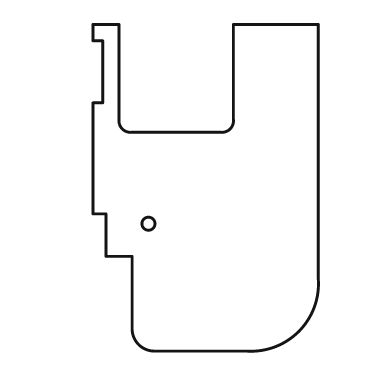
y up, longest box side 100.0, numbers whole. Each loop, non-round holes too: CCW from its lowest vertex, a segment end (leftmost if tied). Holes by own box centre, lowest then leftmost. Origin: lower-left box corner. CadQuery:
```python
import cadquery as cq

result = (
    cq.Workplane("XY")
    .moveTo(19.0, 0.0)
    .lineTo(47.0, 0.0)
    .threePointArc((63.0, 6.0), (69.0, 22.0))
    .lineTo(69.0, 100.0)
    .lineTo(43.0, 100.0)
    .lineTo(43.0, 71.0)
    .threePointArc((42.0, 68.0), (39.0, 67.0))
    .lineTo(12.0, 67.0)
    .threePointArc((9.0, 68.0), (8.0, 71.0))
    .lineTo(8.0, 100.0)
    .lineTo(0.0, 100.0)
    .lineTo(0.0, 95.0)
    .lineTo(3.0, 95.0)
    .lineTo(3.0, 76.0)
    .lineTo(0.0, 76.0)
    .lineTo(0.0, 42.0)
    .lineTo(4.0, 42.0)
    .lineTo(4.0, 29.0)
    .lineTo(12.0, 29.0)
    .lineTo(12.0, 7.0)
    .threePointArc((14.0, 2.0), (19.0, 0.0))
    .close()
    .moveTo(17.0, 39.0)
    .circle(2.0)
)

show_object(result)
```